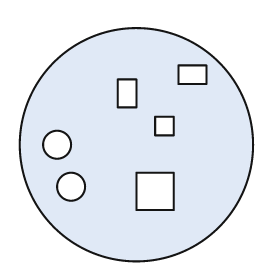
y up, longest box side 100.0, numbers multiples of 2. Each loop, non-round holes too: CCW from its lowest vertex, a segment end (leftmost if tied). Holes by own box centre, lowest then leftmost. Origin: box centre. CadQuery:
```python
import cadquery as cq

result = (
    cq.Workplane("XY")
    .moveTo(0.0, 0.0)
    .circle(50.0)
    .moveTo(0.0, -28.0)
    .lineTo(16.0, -28.0)
    .lineTo(16.0, -12.0)
    .lineTo(0.0, -12.0)
    .close()
    .moveTo(-28.0, -18.0)
    .circle(6.0)
    .moveTo(-34.0, 0.0)
    .circle(6.0)
    .moveTo(8.0, 4.0)
    .lineTo(16.0, 4.0)
    .lineTo(16.0, 12.0)
    .lineTo(8.0, 12.0)
    .close()
    .moveTo(-8.0, 16.0)
    .lineTo(0.0, 16.0)
    .lineTo(0.0, 28.0)
    .lineTo(-8.0, 28.0)
    .close()
    .moveTo(18.0, 26.0)
    .lineTo(30.0, 26.0)
    .lineTo(30.0, 34.0)
    .lineTo(18.0, 34.0)
    .close()
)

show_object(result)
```